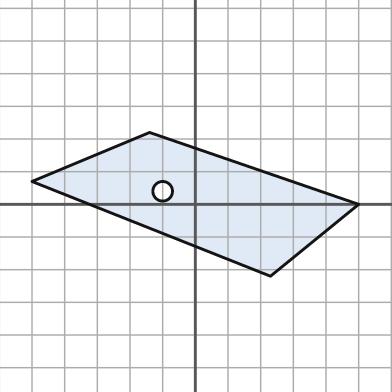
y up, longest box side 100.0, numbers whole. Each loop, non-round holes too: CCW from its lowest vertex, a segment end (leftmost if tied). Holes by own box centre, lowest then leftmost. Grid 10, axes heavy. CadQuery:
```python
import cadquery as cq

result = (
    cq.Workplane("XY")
    .moveTo(23.0, -22.0)
    .lineTo(50.0, 0.0)
    .lineTo(-14.0, 22.0)
    .lineTo(-50.0, 7.0)
    .close()
    .moveTo(-10.0, 4.0)
    .circle(3.0)
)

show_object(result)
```